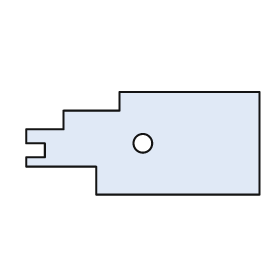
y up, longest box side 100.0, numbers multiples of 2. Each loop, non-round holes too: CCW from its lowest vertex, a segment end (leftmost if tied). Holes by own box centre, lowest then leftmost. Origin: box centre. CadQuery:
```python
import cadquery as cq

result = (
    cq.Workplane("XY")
    .moveTo(-20.0, -22.0)
    .lineTo(50.0, -22.0)
    .lineTo(50.0, 22.0)
    .lineTo(-10.0, 22.0)
    .lineTo(-10.0, 14.0)
    .lineTo(-34.0, 14.0)
    .lineTo(-34.0, 6.0)
    .lineTo(-50.0, 6.0)
    .lineTo(-50.0, 0.0)
    .lineTo(-42.0, 0.0)
    .lineTo(-42.0, -6.0)
    .lineTo(-50.0, -6.0)
    .lineTo(-50.0, -10.0)
    .lineTo(-20.0, -10.0)
    .close()
    .moveTo(0.0, 0.0)
    .circle(4.0)
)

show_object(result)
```